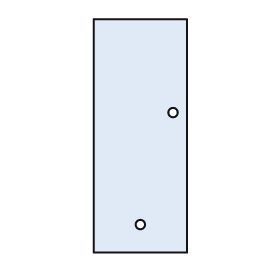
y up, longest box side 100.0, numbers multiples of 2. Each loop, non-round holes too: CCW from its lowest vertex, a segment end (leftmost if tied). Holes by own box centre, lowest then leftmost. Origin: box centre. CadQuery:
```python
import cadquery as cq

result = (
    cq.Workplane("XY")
    .moveTo(-20.0, -50.0)
    .lineTo(20.0, -50.0)
    .lineTo(20.0, 50.0)
    .lineTo(-20.0, 50.0)
    .close()
    .moveTo(0.0, -38.0)
    .circle(2.0)
    .moveTo(14.0, 10.0)
    .circle(2.0)
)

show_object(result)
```